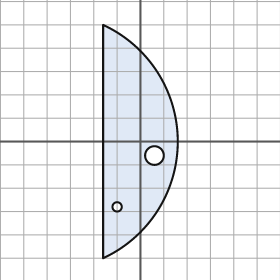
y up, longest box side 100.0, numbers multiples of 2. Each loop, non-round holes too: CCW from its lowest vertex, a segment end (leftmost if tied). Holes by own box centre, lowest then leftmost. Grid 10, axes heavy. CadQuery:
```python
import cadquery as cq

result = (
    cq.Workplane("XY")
    .moveTo(-16.0, -50.0)
    .threePointArc((16.0, 0.0), (-16.0, 50.0))
    .close()
    .moveTo(-10.0, -28.0)
    .circle(2.0)
    .moveTo(6.0, -6.0)
    .circle(4.0)
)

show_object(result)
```